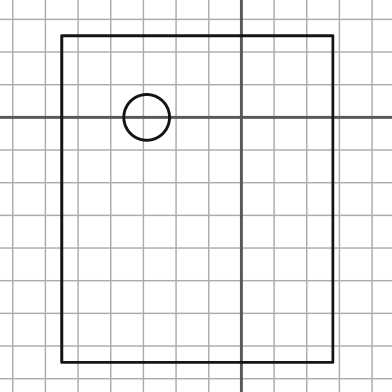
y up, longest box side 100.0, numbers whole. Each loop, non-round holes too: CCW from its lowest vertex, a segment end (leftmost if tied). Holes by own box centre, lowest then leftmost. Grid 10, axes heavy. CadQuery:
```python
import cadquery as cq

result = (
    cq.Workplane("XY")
    .moveTo(-55.0, -75.0)
    .lineTo(28.0, -75.0)
    .lineTo(28.0, 25.0)
    .lineTo(-55.0, 25.0)
    .close()
    .moveTo(-29.0, 0.0)
    .circle(7.0)
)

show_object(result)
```